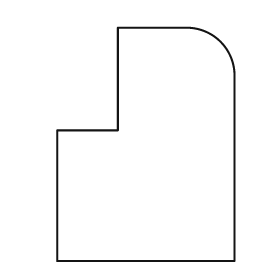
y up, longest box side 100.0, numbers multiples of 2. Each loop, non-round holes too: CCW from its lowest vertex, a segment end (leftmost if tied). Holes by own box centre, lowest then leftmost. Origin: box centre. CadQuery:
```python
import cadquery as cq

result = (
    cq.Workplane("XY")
    .moveTo(-38.0, -50.0)
    .lineTo(38.0, -50.0)
    .lineTo(38.0, 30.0)
    .threePointArc((32.0, 44.0), (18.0, 50.0))
    .lineTo(-12.0, 50.0)
    .lineTo(-12.0, 6.0)
    .lineTo(-38.0, 6.0)
    .close()
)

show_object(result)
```